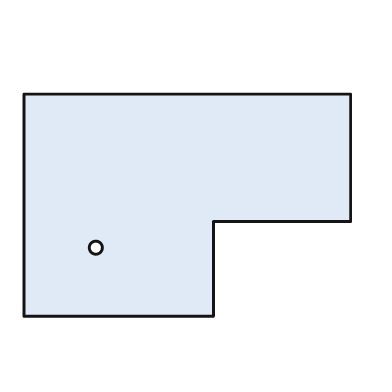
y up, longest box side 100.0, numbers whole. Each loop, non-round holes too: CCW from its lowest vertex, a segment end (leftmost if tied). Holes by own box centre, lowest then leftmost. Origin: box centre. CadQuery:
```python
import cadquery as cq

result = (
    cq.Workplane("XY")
    .moveTo(-50.0, -34.0)
    .lineTo(8.0, -34.0)
    .lineTo(8.0, -5.0)
    .lineTo(50.0, -5.0)
    .lineTo(50.0, 34.0)
    .lineTo(-50.0, 34.0)
    .close()
    .moveTo(-28.0, -13.0)
    .circle(2.0)
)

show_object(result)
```